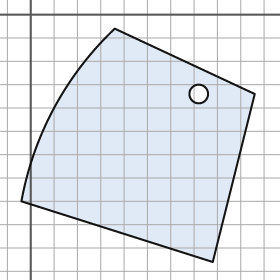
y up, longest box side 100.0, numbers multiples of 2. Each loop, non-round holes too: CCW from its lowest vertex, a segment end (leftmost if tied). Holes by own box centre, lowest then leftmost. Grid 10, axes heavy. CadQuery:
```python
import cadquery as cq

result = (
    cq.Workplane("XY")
    .moveTo(78.0, -106.0)
    .lineTo(96.0, -34.0)
    .lineTo(36.0, -6.0)
    .threePointArc((10.0, -40.0), (-4.0, -80.0))
    .close()
    .moveTo(72.0, -34.0)
    .circle(4.0)
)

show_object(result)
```